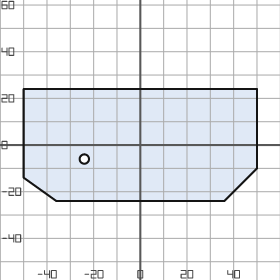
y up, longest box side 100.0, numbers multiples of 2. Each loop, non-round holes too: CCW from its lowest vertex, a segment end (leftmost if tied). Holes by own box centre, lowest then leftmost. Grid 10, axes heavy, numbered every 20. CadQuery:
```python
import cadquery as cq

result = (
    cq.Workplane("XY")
    .moveTo(-36.0, -24.0)
    .lineTo(36.0, -24.0)
    .lineTo(50.0, -10.0)
    .lineTo(50.0, 24.0)
    .lineTo(-50.0, 24.0)
    .lineTo(-50.0, -14.0)
    .close()
    .moveTo(-24.0, -6.0)
    .circle(2.0)
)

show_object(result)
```